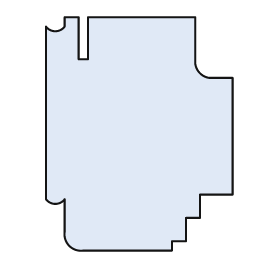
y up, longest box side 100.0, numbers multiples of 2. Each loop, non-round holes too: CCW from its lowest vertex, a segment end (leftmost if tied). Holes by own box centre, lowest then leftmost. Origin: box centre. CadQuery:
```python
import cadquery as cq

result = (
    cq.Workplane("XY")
    .moveTo(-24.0, -50.0)
    .lineTo(14.0, -50.0)
    .lineTo(14.0, -46.0)
    .lineTo(20.0, -46.0)
    .lineTo(20.0, -36.0)
    .lineTo(26.0, -36.0)
    .lineTo(26.0, -26.0)
    .lineTo(40.0, -26.0)
    .lineTo(40.0, 24.0)
    .lineTo(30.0, 24.0)
    .threePointArc((26.0, 26.0), (24.0, 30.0))
    .lineTo(24.0, 50.0)
    .lineTo(-22.0, 50.0)
    .lineTo(-22.0, 32.0)
    .lineTo(-26.0, 32.0)
    .lineTo(-26.0, 50.0)
    .lineTo(-32.0, 50.0)
    .lineTo(-32.0, 46.0)
    .threePointArc((-36.0, 44.0), (-40.0, 46.0))
    .lineTo(-40.0, -28.0)
    .threePointArc((-36.0, -30.0), (-32.0, -28.0))
    .lineTo(-32.0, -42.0)
    .threePointArc((-30.0, -48.0), (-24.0, -50.0))
    .close()
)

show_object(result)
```